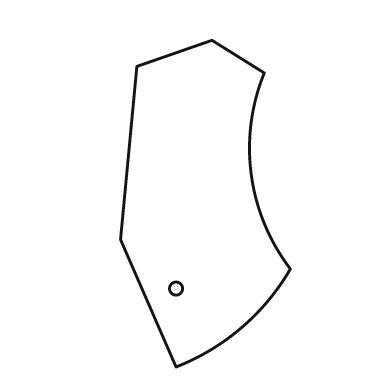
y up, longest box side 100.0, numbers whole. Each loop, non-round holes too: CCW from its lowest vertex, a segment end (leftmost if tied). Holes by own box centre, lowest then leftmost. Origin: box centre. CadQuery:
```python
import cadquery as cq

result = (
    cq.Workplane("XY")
    .moveTo(-9.0, -50.0)
    .threePointArc((11.0, -38.0), (26.0, -20.0))
    .threePointArc((14.0, 9.0), (18.0, 40.0))
    .lineTo(2.0, 50.0)
    .lineTo(-21.0, 42.0)
    .lineTo(-26.0, -11.0)
    .close()
    .moveTo(-9.0, -26.0)
    .circle(2.0)
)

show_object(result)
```